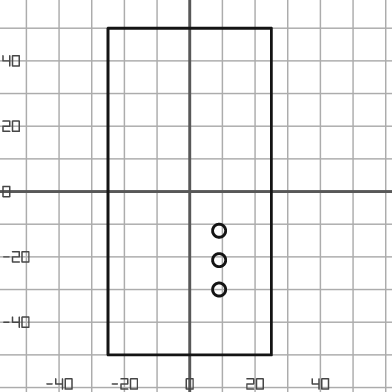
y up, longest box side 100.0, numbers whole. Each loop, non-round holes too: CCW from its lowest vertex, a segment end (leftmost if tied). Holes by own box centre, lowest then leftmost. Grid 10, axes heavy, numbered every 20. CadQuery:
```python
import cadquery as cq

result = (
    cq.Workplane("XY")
    .moveTo(-25.0, -50.0)
    .lineTo(25.0, -50.0)
    .lineTo(25.0, 50.0)
    .lineTo(-25.0, 50.0)
    .close()
    .moveTo(9.0, -30.0)
    .circle(2.0)
    .moveTo(9.0, -21.0)
    .circle(2.0)
    .moveTo(9.0, -12.0)
    .circle(2.0)
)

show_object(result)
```